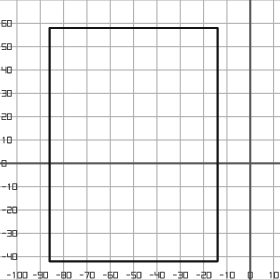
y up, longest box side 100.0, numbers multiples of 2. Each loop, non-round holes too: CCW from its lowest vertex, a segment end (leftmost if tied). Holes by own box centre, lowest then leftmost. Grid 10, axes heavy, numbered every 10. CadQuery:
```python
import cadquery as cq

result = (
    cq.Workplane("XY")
    .moveTo(-86.0, -42.0)
    .lineTo(-14.0, -42.0)
    .lineTo(-14.0, 58.0)
    .lineTo(-86.0, 58.0)
    .close()
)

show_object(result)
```